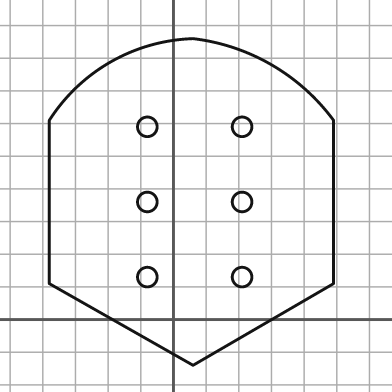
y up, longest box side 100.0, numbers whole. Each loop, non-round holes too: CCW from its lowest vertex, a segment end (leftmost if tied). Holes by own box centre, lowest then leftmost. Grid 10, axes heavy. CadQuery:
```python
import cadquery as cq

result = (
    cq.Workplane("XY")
    .moveTo(6.0, -14.0)
    .lineTo(49.0, 11.0)
    .lineTo(49.0, 61.0)
    .threePointArc((30.0, 78.0), (6.0, 86.0))
    .threePointArc((-19.0, 79.0), (-38.0, 61.0))
    .lineTo(-38.0, 11.0)
    .close()
    .moveTo(-8.0, 13.0)
    .circle(3.0)
    .moveTo(21.0, 13.0)
    .circle(3.0)
    .moveTo(-8.0, 36.0)
    .circle(3.0)
    .moveTo(21.0, 36.0)
    .circle(3.0)
    .moveTo(-8.0, 59.0)
    .circle(3.0)
    .moveTo(21.0, 59.0)
    .circle(3.0)
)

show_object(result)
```